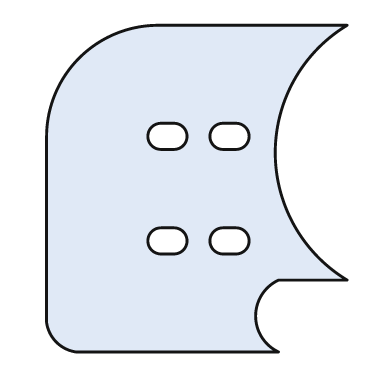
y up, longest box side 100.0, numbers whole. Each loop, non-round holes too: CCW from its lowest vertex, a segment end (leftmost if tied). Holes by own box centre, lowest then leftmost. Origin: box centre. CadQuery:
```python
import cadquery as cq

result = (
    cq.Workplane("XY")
    .moveTo(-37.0, -50.0)
    .lineTo(25.0, -50.0)
    .threePointArc((18.0, -39.0), (25.0, -28.0))
    .lineTo(46.0, -28.0)
    .threePointArc((24.0, 11.0), (46.0, 50.0))
    .lineTo(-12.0, 50.0)
    .threePointArc((-36.0, 40.0), (-46.0, 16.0))
    .lineTo(-46.0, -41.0)
    .threePointArc((-43.0, -47.0), (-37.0, -50.0))
    .close()
    .moveTo(-11.0, -20.0)
    .lineTo(-7.0, -20.0)
    .threePointArc((-3.0, -16.0), (-7.0, -12.0))
    .lineTo(-11.0, -12.0)
    .threePointArc((-15.0, -16.0), (-11.0, -20.0))
    .close()
    .moveTo(8.0, -20.0)
    .lineTo(12.0, -20.0)
    .threePointArc((16.0, -16.0), (12.0, -12.0))
    .lineTo(8.0, -12.0)
    .threePointArc((4.0, -16.0), (8.0, -20.0))
    .close()
    .moveTo(-11.0, 12.0)
    .lineTo(-7.0, 12.0)
    .threePointArc((-3.0, 16.0), (-7.0, 20.0))
    .lineTo(-11.0, 20.0)
    .threePointArc((-15.0, 16.0), (-11.0, 12.0))
    .close()
    .moveTo(8.0, 12.0)
    .lineTo(12.0, 12.0)
    .threePointArc((16.0, 16.0), (12.0, 20.0))
    .lineTo(8.0, 20.0)
    .threePointArc((4.0, 16.0), (8.0, 12.0))
    .close()
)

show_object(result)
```